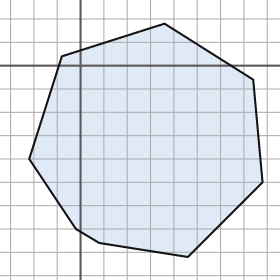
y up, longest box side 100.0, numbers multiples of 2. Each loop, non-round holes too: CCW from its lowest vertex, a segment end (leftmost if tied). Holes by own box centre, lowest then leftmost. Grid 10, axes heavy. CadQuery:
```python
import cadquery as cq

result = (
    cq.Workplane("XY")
    .moveTo(46.0, -82.0)
    .lineTo(78.0, -50.0)
    .lineTo(74.0, -6.0)
    .lineTo(36.0, 18.0)
    .lineTo(-8.0, 4.0)
    .lineTo(-22.0, -40.0)
    .lineTo(-2.0, -70.0)
    .lineTo(8.0, -76.0)
    .close()
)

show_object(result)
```